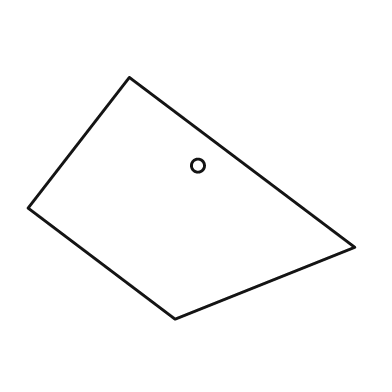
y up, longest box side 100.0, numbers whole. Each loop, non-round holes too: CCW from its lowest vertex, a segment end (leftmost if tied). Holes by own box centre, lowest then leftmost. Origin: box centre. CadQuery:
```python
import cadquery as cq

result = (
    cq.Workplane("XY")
    .moveTo(-5.0, -37.0)
    .lineTo(50.0, -15.0)
    .lineTo(-19.0, 37.0)
    .lineTo(-50.0, -3.0)
    .close()
    .moveTo(2.0, 10.0)
    .circle(2.0)
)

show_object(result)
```